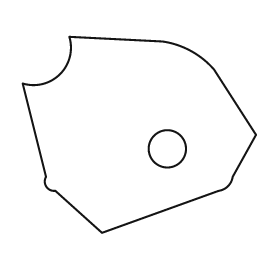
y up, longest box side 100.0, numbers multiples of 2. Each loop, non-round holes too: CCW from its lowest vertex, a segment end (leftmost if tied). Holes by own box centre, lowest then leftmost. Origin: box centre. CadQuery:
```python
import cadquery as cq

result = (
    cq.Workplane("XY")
    .moveTo(-16.0, -42.0)
    .lineTo(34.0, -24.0)
    .threePointArc((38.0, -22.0), (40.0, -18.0))
    .lineTo(50.0, 0.0)
    .lineTo(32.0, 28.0)
    .threePointArc((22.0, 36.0), (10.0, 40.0))
    .lineTo(-30.0, 42.0)
    .threePointArc((-34.0, 26.0), (-50.0, 22.0))
    .lineTo(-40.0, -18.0)
    .threePointArc((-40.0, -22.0), (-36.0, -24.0))
    .close()
    .moveTo(12.0, -6.0)
    .circle(8.0)
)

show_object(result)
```